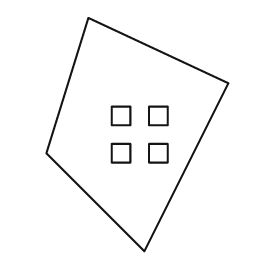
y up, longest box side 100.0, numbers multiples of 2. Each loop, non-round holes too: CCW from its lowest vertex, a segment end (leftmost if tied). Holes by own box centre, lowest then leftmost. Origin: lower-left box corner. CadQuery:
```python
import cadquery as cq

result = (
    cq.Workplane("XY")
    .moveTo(42.0, 0.0)
    .lineTo(78.0, 72.0)
    .lineTo(18.0, 100.0)
    .lineTo(0.0, 42.0)
    .close()
    .moveTo(28.0, 38.0)
    .lineTo(36.0, 38.0)
    .lineTo(36.0, 46.0)
    .lineTo(28.0, 46.0)
    .close()
    .moveTo(44.0, 38.0)
    .lineTo(52.0, 38.0)
    .lineTo(52.0, 46.0)
    .lineTo(44.0, 46.0)
    .close()
    .moveTo(28.0, 54.0)
    .lineTo(36.0, 54.0)
    .lineTo(36.0, 62.0)
    .lineTo(28.0, 62.0)
    .close()
    .moveTo(44.0, 54.0)
    .lineTo(52.0, 54.0)
    .lineTo(52.0, 62.0)
    .lineTo(44.0, 62.0)
    .close()
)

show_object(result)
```